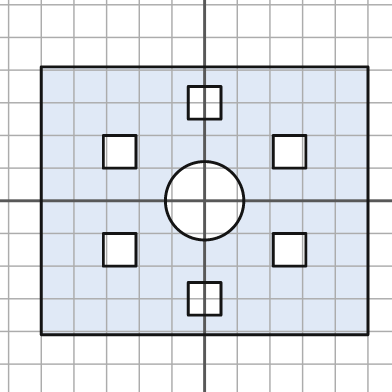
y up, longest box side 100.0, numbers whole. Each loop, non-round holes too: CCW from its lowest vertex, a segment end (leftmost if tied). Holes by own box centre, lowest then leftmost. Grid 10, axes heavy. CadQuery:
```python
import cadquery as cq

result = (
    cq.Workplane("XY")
    .moveTo(-50.0, -41.0)
    .lineTo(50.0, -41.0)
    .lineTo(50.0, 41.0)
    .lineTo(-50.0, 41.0)
    .close()
    .moveTo(-5.0, -35.0)
    .lineTo(5.0, -35.0)
    .lineTo(5.0, -25.0)
    .lineTo(-5.0, -25.0)
    .close()
    .moveTo(-31.0, -20.0)
    .lineTo(-21.0, -20.0)
    .lineTo(-21.0, -10.0)
    .lineTo(-31.0, -10.0)
    .close()
    .moveTo(21.0, -20.0)
    .lineTo(31.0, -20.0)
    .lineTo(31.0, -10.0)
    .lineTo(21.0, -10.0)
    .close()
    .moveTo(0.0, 0.0)
    .circle(12.0)
    .moveTo(-31.0, 10.0)
    .lineTo(-21.0, 10.0)
    .lineTo(-21.0, 20.0)
    .lineTo(-31.0, 20.0)
    .close()
    .moveTo(21.0, 10.0)
    .lineTo(31.0, 10.0)
    .lineTo(31.0, 20.0)
    .lineTo(21.0, 20.0)
    .close()
    .moveTo(-5.0, 25.0)
    .lineTo(5.0, 25.0)
    .lineTo(5.0, 35.0)
    .lineTo(-5.0, 35.0)
    .close()
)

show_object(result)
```